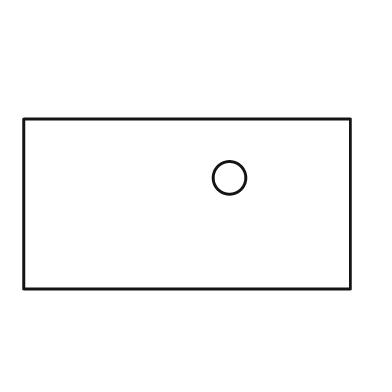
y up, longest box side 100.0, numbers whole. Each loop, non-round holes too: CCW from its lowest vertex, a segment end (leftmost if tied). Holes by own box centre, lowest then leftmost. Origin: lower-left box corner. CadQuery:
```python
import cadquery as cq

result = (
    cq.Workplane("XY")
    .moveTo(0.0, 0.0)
    .lineTo(100.0, 0.0)
    .lineTo(100.0, 52.0)
    .lineTo(0.0, 52.0)
    .close()
    .moveTo(63.0, 34.0)
    .circle(5.0)
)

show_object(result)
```